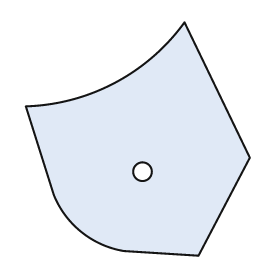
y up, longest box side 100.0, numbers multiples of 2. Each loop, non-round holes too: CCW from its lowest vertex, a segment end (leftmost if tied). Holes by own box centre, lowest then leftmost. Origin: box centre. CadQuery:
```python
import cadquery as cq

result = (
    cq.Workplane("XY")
    .moveTo(26.0, -50.0)
    .lineTo(48.0, -8.0)
    .lineTo(20.0, 50.0)
    .threePointArc((-10.0, 24.0), (-48.0, 14.0))
    .lineTo(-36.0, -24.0)
    .threePointArc((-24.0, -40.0), (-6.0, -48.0))
    .close()
    .moveTo(2.0, -14.0)
    .circle(4.0)
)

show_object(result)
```